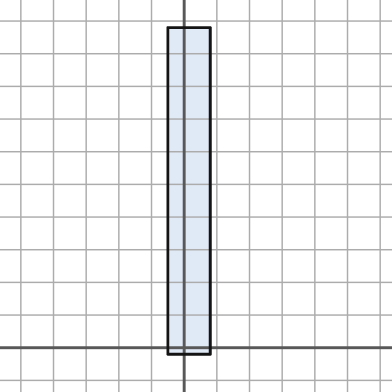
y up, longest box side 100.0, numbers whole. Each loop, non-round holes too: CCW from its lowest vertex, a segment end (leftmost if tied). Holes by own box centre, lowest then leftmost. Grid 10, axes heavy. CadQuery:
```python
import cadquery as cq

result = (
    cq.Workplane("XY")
    .moveTo(-5.0, -2.0)
    .lineTo(8.0, -2.0)
    .lineTo(8.0, 98.0)
    .lineTo(-5.0, 98.0)
    .close()
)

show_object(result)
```